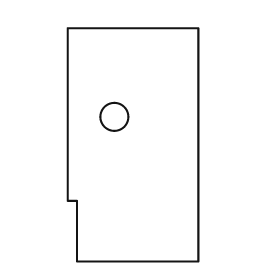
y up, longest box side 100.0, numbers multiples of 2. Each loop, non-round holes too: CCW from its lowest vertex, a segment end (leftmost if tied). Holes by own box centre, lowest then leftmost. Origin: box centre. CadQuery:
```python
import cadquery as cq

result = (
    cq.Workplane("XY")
    .moveTo(-24.0, -50.0)
    .lineTo(28.0, -50.0)
    .lineTo(28.0, 50.0)
    .lineTo(-28.0, 50.0)
    .lineTo(-28.0, -24.0)
    .lineTo(-24.0, -24.0)
    .close()
    .moveTo(-8.0, 12.0)
    .circle(6.0)
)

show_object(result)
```